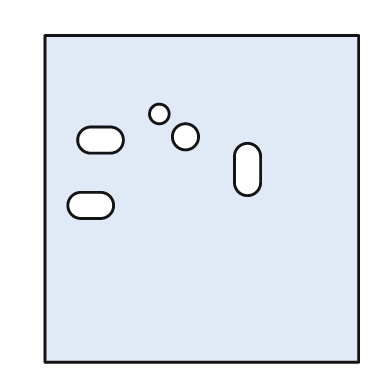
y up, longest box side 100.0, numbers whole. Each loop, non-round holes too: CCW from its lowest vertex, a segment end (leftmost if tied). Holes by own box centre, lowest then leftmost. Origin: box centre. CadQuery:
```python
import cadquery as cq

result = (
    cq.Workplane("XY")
    .moveTo(-48.0, -50.0)
    .lineTo(48.0, -50.0)
    .lineTo(48.0, 50.0)
    .lineTo(-48.0, 50.0)
    .close()
    .moveTo(-37.0, -6.0)
    .lineTo(-31.0, -6.0)
    .threePointArc((-27.0, -2.0), (-31.0, 2.0))
    .lineTo(-37.0, 2.0)
    .threePointArc((-41.0, -2.0), (-37.0, -6.0))
    .close()
    .moveTo(10.0, 5.0)
    .threePointArc((14.0, 1.0), (18.0, 5.0))
    .lineTo(18.0, 13.0)
    .threePointArc((14.0, 17.0), (10.0, 13.0))
    .close()
    .moveTo(-34.0, 14.0)
    .lineTo(-28.0, 14.0)
    .threePointArc((-24.0, 18.0), (-28.0, 22.0))
    .lineTo(-34.0, 22.0)
    .threePointArc((-38.0, 18.0), (-34.0, 14.0))
    .close()
    .moveTo(-5.0, 19.0)
    .circle(4.0)
    .moveTo(-13.0, 26.0)
    .circle(3.0)
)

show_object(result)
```